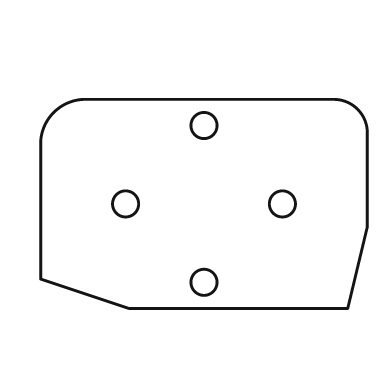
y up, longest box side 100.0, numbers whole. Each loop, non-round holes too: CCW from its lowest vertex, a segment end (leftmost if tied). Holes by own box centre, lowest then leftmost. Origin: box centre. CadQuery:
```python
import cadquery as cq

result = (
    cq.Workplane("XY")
    .moveTo(-23.0, -32.0)
    .lineTo(44.0, -32.0)
    .lineTo(50.0, -7.0)
    .lineTo(50.0, 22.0)
    .threePointArc((47.0, 29.0), (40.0, 32.0))
    .lineTo(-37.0, 32.0)
    .threePointArc((-46.0, 28.0), (-50.0, 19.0))
    .lineTo(-50.0, -23.0)
    .close()
    .moveTo(0.0, -24.0)
    .circle(4.0)
    .moveTo(-24.0, 0.0)
    .circle(4.0)
    .moveTo(24.0, 0.0)
    .circle(4.0)
    .moveTo(0.0, 24.0)
    .circle(4.0)
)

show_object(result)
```